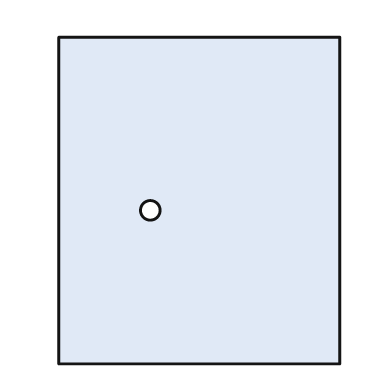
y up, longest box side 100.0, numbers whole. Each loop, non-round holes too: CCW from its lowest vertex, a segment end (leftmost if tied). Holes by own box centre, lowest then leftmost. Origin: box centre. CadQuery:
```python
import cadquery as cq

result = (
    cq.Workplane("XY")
    .moveTo(-43.0, -50.0)
    .lineTo(43.0, -50.0)
    .lineTo(43.0, 50.0)
    .lineTo(-43.0, 50.0)
    .close()
    .moveTo(-15.0, -3.0)
    .circle(3.0)
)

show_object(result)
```